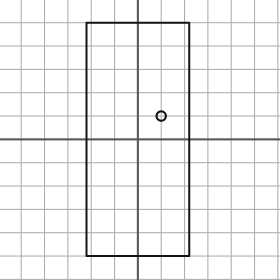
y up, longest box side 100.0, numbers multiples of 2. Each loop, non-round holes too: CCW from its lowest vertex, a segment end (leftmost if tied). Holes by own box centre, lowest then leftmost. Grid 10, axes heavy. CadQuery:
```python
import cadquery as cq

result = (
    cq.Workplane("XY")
    .moveTo(-22.0, -50.0)
    .lineTo(22.0, -50.0)
    .lineTo(22.0, 50.0)
    .lineTo(-22.0, 50.0)
    .close()
    .moveTo(10.0, 10.0)
    .circle(2.0)
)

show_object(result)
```